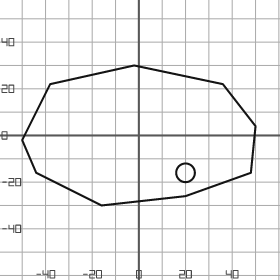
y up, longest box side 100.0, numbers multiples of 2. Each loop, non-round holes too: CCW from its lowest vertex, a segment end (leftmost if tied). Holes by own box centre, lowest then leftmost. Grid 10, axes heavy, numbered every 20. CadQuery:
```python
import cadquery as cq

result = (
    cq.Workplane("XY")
    .moveTo(-16.0, -30.0)
    .lineTo(20.0, -26.0)
    .lineTo(48.0, -16.0)
    .lineTo(50.0, 4.0)
    .lineTo(36.0, 22.0)
    .lineTo(-2.0, 30.0)
    .lineTo(-38.0, 22.0)
    .lineTo(-50.0, -2.0)
    .lineTo(-44.0, -16.0)
    .close()
    .moveTo(20.0, -16.0)
    .circle(4.0)
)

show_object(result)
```